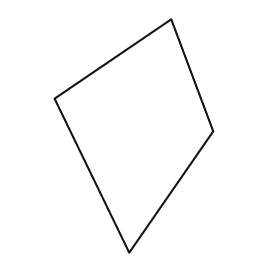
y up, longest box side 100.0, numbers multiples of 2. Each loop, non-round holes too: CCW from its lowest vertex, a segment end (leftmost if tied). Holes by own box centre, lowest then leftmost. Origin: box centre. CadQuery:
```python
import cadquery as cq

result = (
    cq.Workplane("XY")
    .moveTo(-2.0, -50.0)
    .lineTo(34.0, 2.0)
    .lineTo(16.0, 50.0)
    .lineTo(-34.0, 16.0)
    .close()
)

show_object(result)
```